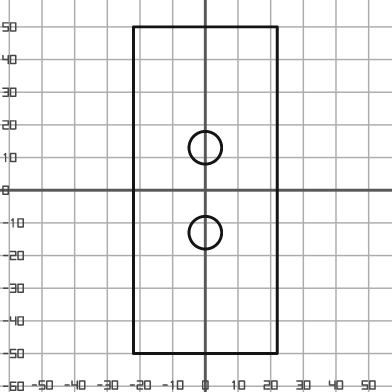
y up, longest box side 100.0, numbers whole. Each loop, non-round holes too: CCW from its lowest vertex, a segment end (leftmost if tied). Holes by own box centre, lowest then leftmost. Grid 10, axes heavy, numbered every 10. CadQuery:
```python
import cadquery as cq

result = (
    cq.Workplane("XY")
    .moveTo(-22.0, -50.0)
    .lineTo(22.0, -50.0)
    .lineTo(22.0, 50.0)
    .lineTo(-22.0, 50.0)
    .close()
    .moveTo(0.0, -13.0)
    .circle(5.0)
    .moveTo(0.0, 13.0)
    .circle(5.0)
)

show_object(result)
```